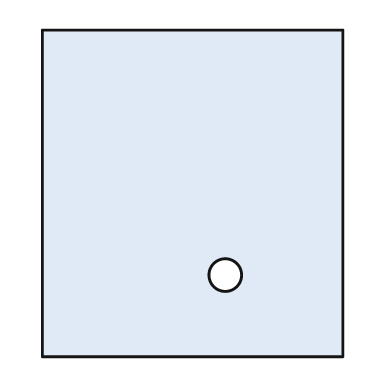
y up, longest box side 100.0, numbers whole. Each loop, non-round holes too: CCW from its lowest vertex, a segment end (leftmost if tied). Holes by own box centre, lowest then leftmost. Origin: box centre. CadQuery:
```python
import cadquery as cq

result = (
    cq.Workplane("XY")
    .moveTo(-46.0, -50.0)
    .lineTo(46.0, -50.0)
    .lineTo(46.0, 50.0)
    .lineTo(-46.0, 50.0)
    .close()
    .moveTo(10.0, -25.0)
    .circle(5.0)
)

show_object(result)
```